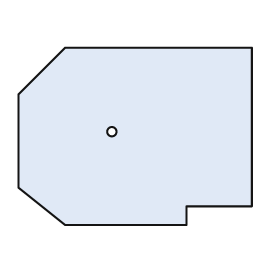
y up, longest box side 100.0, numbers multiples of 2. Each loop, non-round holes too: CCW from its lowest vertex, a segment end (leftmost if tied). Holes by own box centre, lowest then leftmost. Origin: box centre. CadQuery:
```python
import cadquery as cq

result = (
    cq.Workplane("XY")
    .moveTo(-30.0, -38.0)
    .lineTo(22.0, -38.0)
    .lineTo(22.0, -30.0)
    .lineTo(50.0, -30.0)
    .lineTo(50.0, 38.0)
    .lineTo(-30.0, 38.0)
    .lineTo(-50.0, 18.0)
    .lineTo(-50.0, -22.0)
    .close()
    .moveTo(-10.0, 2.0)
    .circle(2.0)
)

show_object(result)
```